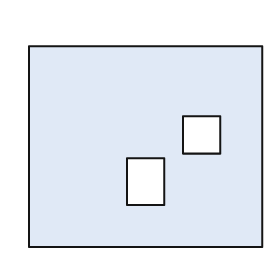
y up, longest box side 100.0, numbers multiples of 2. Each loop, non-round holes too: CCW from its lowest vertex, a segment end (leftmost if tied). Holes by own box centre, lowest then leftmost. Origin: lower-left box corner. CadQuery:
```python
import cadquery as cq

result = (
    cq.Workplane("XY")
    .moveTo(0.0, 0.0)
    .lineTo(100.0, 0.0)
    .lineTo(100.0, 86.0)
    .lineTo(0.0, 86.0)
    .close()
    .moveTo(42.0, 18.0)
    .lineTo(58.0, 18.0)
    .lineTo(58.0, 38.0)
    .lineTo(42.0, 38.0)
    .close()
    .moveTo(66.0, 40.0)
    .lineTo(82.0, 40.0)
    .lineTo(82.0, 56.0)
    .lineTo(66.0, 56.0)
    .close()
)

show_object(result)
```